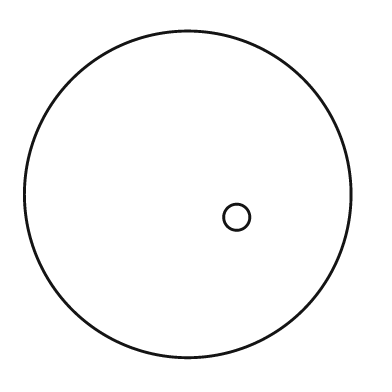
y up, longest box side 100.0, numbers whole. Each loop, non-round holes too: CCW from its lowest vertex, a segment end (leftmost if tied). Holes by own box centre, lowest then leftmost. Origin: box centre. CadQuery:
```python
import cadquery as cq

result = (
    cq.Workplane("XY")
    .moveTo(0.0, 0.0)
    .circle(50.0)
    .moveTo(15.0, -7.0)
    .circle(4.0)
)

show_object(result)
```